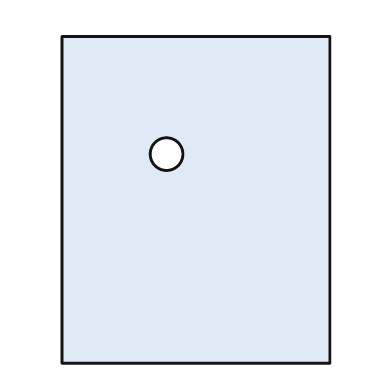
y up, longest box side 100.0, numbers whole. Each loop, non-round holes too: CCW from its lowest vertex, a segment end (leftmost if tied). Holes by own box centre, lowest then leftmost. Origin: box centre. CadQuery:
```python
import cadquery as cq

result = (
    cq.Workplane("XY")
    .moveTo(-41.0, -50.0)
    .lineTo(41.0, -50.0)
    .lineTo(41.0, 50.0)
    .lineTo(-41.0, 50.0)
    .close()
    .moveTo(-9.0, 14.0)
    .circle(5.0)
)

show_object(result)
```